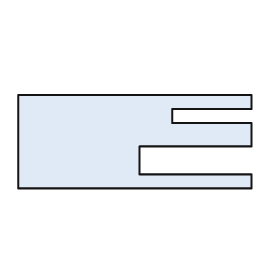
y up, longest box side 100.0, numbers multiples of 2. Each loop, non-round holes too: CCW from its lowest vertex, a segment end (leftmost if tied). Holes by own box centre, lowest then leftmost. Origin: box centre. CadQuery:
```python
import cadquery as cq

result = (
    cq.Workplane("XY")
    .moveTo(-50.0, -20.0)
    .lineTo(50.0, -20.0)
    .lineTo(50.0, -14.0)
    .lineTo(2.0, -14.0)
    .lineTo(2.0, -2.0)
    .lineTo(50.0, -2.0)
    .lineTo(50.0, 8.0)
    .lineTo(16.0, 8.0)
    .lineTo(16.0, 14.0)
    .lineTo(50.0, 14.0)
    .lineTo(50.0, 20.0)
    .lineTo(-50.0, 20.0)
    .close()
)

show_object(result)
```